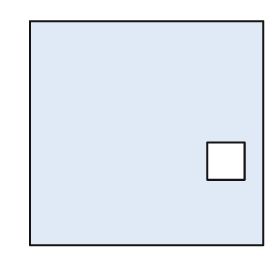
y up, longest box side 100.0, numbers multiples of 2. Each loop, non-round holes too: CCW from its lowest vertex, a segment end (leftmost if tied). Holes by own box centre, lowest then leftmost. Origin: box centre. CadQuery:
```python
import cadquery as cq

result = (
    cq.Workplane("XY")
    .moveTo(-50.0, -48.0)
    .lineTo(50.0, -48.0)
    .lineTo(50.0, 48.0)
    .lineTo(-50.0, 48.0)
    .close()
    .moveTo(26.0, -20.0)
    .lineTo(42.0, -20.0)
    .lineTo(42.0, -4.0)
    .lineTo(26.0, -4.0)
    .close()
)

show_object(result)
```